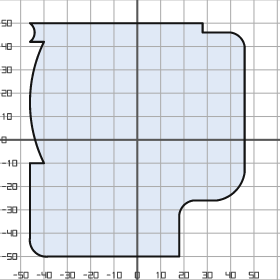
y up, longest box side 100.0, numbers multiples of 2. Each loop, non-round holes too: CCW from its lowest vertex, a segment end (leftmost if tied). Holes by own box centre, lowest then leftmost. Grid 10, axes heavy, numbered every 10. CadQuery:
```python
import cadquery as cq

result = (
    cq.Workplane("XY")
    .moveTo(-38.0, -50.0)
    .lineTo(18.0, -50.0)
    .lineTo(18.0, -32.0)
    .threePointArc((20.0, -28.0), (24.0, -26.0))
    .lineTo(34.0, -26.0)
    .threePointArc((42.0, -22.0), (46.0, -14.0))
    .lineTo(46.0, 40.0)
    .threePointArc((44.0, 44.0), (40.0, 46.0))
    .lineTo(28.0, 46.0)
    .lineTo(28.0, 50.0)
    .lineTo(-46.0, 50.0)
    .threePointArc((-44.0, 46.0), (-46.0, 42.0))
    .lineTo(-40.0, 42.0)
    .threePointArc((-46.0, 16.0), (-40.0, -10.0))
    .lineTo(-46.0, -10.0)
    .lineTo(-46.0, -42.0)
    .threePointArc((-44.0, -48.0), (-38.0, -50.0))
    .close()
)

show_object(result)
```